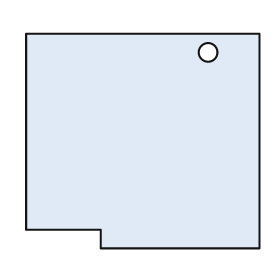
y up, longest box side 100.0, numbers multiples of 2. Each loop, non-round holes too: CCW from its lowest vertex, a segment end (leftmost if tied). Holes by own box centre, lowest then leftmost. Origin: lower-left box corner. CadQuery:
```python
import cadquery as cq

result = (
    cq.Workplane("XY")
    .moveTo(32.0, 0.0)
    .lineTo(100.0, 0.0)
    .lineTo(100.0, 92.0)
    .lineTo(0.0, 92.0)
    .lineTo(0.0, 8.0)
    .lineTo(32.0, 8.0)
    .close()
    .moveTo(78.0, 84.0)
    .circle(4.0)
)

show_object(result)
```